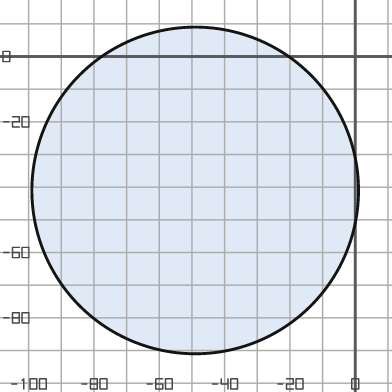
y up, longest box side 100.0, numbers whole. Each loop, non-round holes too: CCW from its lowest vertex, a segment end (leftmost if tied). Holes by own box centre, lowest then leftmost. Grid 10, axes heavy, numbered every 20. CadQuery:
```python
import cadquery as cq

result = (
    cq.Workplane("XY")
    .moveTo(-49.0, -41.0)
    .circle(50.0)
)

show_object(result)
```